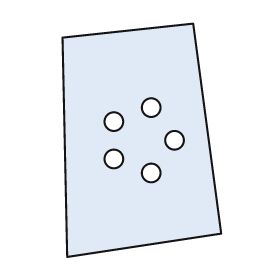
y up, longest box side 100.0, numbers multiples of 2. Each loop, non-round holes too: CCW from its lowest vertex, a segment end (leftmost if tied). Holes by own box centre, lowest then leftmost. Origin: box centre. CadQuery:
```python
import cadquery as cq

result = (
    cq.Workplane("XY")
    .moveTo(-32.0, -50.0)
    .lineTo(34.0, -40.0)
    .lineTo(22.0, 50.0)
    .lineTo(-34.0, 44.0)
    .close()
    .moveTo(4.0, -14.0)
    .circle(4.0)
    .moveTo(-12.0, -8.0)
    .circle(4.0)
    .moveTo(14.0, 0.0)
    .circle(4.0)
    .moveTo(-12.0, 8.0)
    .circle(4.0)
    .moveTo(4.0, 14.0)
    .circle(4.0)
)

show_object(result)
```